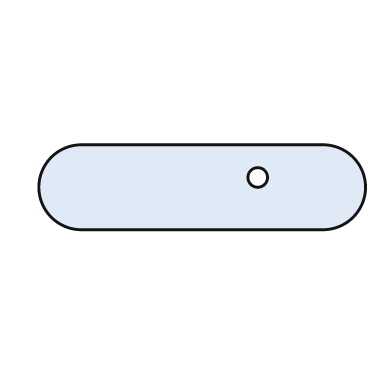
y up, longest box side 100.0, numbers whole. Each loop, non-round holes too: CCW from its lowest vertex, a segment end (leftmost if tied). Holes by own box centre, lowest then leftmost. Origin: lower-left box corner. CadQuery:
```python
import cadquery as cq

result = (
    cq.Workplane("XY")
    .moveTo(13.0, 0.0)
    .lineTo(87.0, 0.0)
    .threePointArc((100.0, 13.0), (87.0, 26.0))
    .lineTo(13.0, 26.0)
    .threePointArc((0.0, 13.0), (13.0, 0.0))
    .close()
    .moveTo(67.0, 16.0)
    .circle(3.0)
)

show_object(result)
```